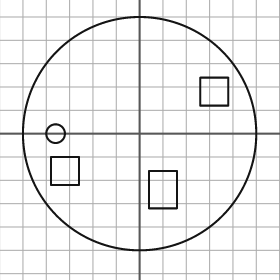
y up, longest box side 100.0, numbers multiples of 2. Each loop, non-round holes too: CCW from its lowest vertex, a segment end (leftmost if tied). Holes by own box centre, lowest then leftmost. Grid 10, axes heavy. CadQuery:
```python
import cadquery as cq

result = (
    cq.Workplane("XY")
    .moveTo(0.0, 0.0)
    .circle(50.0)
    .moveTo(4.0, -32.0)
    .lineTo(16.0, -32.0)
    .lineTo(16.0, -16.0)
    .lineTo(4.0, -16.0)
    .close()
    .moveTo(-38.0, -22.0)
    .lineTo(-26.0, -22.0)
    .lineTo(-26.0, -10.0)
    .lineTo(-38.0, -10.0)
    .close()
    .moveTo(-36.0, 0.0)
    .circle(4.0)
    .moveTo(26.0, 12.0)
    .lineTo(38.0, 12.0)
    .lineTo(38.0, 24.0)
    .lineTo(26.0, 24.0)
    .close()
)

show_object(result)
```